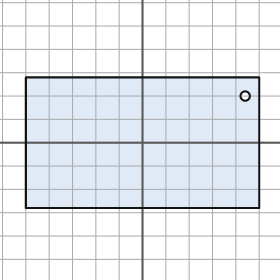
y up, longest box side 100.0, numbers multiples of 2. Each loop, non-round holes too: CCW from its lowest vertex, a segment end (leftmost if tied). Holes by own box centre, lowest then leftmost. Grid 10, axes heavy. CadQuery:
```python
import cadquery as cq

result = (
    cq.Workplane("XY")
    .moveTo(-50.0, -28.0)
    .lineTo(50.0, -28.0)
    .lineTo(50.0, 28.0)
    .lineTo(-50.0, 28.0)
    .close()
    .moveTo(44.0, 20.0)
    .circle(2.0)
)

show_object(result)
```